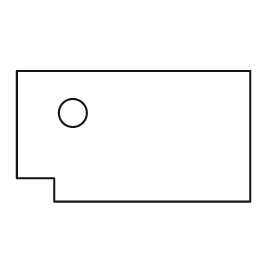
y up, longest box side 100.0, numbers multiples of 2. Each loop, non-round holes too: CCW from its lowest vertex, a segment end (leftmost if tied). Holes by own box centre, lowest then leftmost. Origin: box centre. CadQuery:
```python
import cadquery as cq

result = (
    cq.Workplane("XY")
    .moveTo(-34.0, -28.0)
    .lineTo(50.0, -28.0)
    .lineTo(50.0, 28.0)
    .lineTo(-50.0, 28.0)
    .lineTo(-50.0, -18.0)
    .lineTo(-34.0, -18.0)
    .close()
    .moveTo(-26.0, 10.0)
    .circle(6.0)
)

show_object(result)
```